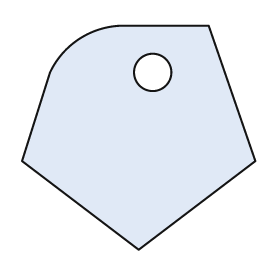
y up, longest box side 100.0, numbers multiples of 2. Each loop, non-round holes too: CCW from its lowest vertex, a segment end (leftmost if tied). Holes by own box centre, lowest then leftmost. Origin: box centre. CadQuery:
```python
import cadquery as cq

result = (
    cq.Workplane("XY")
    .moveTo(0.0, -48.0)
    .lineTo(50.0, -10.0)
    .lineTo(30.0, 48.0)
    .lineTo(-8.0, 48.0)
    .threePointArc((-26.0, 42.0), (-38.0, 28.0))
    .lineTo(-50.0, -10.0)
    .close()
    .moveTo(6.0, 28.0)
    .circle(8.0)
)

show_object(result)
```